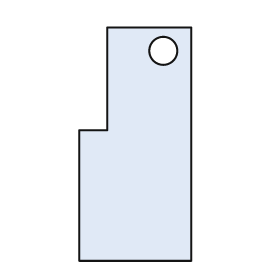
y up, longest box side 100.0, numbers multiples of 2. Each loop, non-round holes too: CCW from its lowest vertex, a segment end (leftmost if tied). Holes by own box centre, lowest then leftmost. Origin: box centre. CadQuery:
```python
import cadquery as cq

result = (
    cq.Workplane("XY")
    .moveTo(-24.0, -50.0)
    .lineTo(24.0, -50.0)
    .lineTo(24.0, 50.0)
    .lineTo(-12.0, 50.0)
    .lineTo(-12.0, 6.0)
    .lineTo(-24.0, 6.0)
    .close()
    .moveTo(12.0, 40.0)
    .circle(6.0)
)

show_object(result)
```